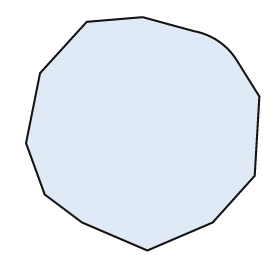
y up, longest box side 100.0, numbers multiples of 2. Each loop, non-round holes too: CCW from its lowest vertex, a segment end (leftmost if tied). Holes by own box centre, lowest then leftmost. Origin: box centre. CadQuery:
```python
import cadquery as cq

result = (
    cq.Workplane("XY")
    .moveTo(2.0, -50.0)
    .lineTo(30.0, -38.0)
    .lineTo(48.0, -18.0)
    .lineTo(50.0, 16.0)
    .lineTo(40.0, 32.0)
    .threePointArc((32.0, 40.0), (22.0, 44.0))
    .lineTo(0.0, 50.0)
    .lineTo(-24.0, 48.0)
    .lineTo(-44.0, 26.0)
    .lineTo(-50.0, -4.0)
    .lineTo(-42.0, -26.0)
    .lineTo(-26.0, -38.0)
    .close()
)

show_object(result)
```